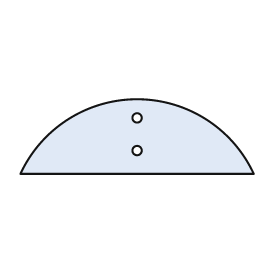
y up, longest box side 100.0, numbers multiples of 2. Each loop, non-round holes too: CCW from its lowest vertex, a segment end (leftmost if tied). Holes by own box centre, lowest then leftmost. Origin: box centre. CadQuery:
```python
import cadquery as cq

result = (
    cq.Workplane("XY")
    .moveTo(-50.0, -16.0)
    .lineTo(50.0, -16.0)
    .threePointArc((0.0, 16.0), (-50.0, -16.0))
    .close()
    .moveTo(0.0, -6.0)
    .circle(2.0)
    .moveTo(0.0, 8.0)
    .circle(2.0)
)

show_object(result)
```